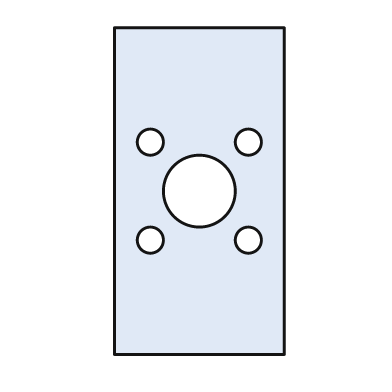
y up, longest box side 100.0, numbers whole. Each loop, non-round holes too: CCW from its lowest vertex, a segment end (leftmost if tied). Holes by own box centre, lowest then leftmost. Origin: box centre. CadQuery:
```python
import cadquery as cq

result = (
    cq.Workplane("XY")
    .moveTo(-26.0, -50.0)
    .lineTo(26.0, -50.0)
    .lineTo(26.0, 50.0)
    .lineTo(-26.0, 50.0)
    .close()
    .moveTo(-15.0, -15.0)
    .circle(4.0)
    .moveTo(15.0, -15.0)
    .circle(4.0)
    .moveTo(0.0, 0.0)
    .circle(11.0)
    .moveTo(-15.0, 15.0)
    .circle(4.0)
    .moveTo(15.0, 15.0)
    .circle(4.0)
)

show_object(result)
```